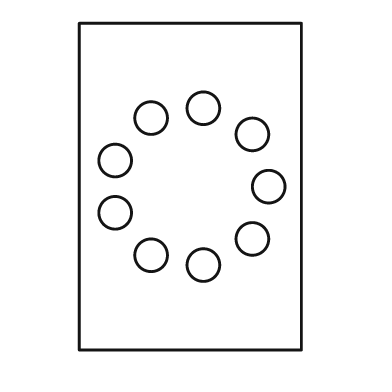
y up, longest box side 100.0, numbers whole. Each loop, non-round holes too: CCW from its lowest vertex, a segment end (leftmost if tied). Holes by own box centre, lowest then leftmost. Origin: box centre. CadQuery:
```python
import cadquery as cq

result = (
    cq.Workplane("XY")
    .moveTo(-34.0, -50.0)
    .lineTo(34.0, -50.0)
    .lineTo(34.0, 50.0)
    .lineTo(-34.0, 50.0)
    .close()
    .moveTo(4.0, -24.0)
    .circle(5.0)
    .moveTo(-12.0, -21.0)
    .circle(5.0)
    .moveTo(19.0, -16.0)
    .circle(5.0)
    .moveTo(-23.0, -8.0)
    .circle(5.0)
    .moveTo(24.0, 0.0)
    .circle(5.0)
    .moveTo(-23.0, 8.0)
    .circle(5.0)
    .moveTo(19.0, 16.0)
    .circle(5.0)
    .moveTo(-12.0, 21.0)
    .circle(5.0)
    .moveTo(4.0, 24.0)
    .circle(5.0)
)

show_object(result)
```